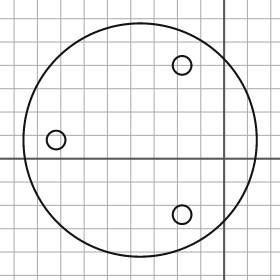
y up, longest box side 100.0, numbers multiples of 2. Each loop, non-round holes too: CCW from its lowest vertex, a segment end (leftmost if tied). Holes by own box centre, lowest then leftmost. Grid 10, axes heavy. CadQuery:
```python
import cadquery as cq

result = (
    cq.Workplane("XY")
    .moveTo(-36.0, 8.0)
    .circle(50.0)
    .moveTo(-18.0, -24.0)
    .circle(4.0)
    .moveTo(-72.0, 8.0)
    .circle(4.0)
    .moveTo(-18.0, 40.0)
    .circle(4.0)
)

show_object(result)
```